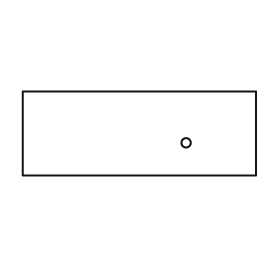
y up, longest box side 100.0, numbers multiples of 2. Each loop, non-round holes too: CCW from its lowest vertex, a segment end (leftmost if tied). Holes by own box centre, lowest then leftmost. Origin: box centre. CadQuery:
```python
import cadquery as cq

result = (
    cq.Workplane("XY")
    .moveTo(-50.0, -18.0)
    .lineTo(50.0, -18.0)
    .lineTo(50.0, 18.0)
    .lineTo(-50.0, 18.0)
    .close()
    .moveTo(20.0, -4.0)
    .circle(2.0)
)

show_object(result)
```